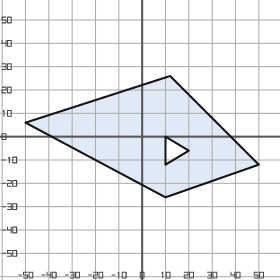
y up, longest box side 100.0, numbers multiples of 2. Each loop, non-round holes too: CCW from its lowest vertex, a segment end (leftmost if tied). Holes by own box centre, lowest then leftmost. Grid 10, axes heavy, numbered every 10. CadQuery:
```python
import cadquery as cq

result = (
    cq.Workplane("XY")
    .moveTo(10.0, -26.0)
    .lineTo(50.0, -12.0)
    .lineTo(12.0, 26.0)
    .lineTo(-50.0, 6.0)
    .close()
    .moveTo(10.0, -12.0)
    .lineTo(20.0, -6.0)
    .lineTo(10.0, 0.0)
    .close()
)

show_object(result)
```